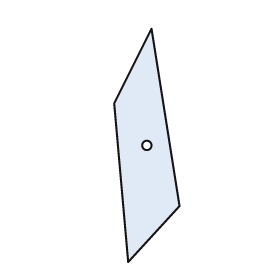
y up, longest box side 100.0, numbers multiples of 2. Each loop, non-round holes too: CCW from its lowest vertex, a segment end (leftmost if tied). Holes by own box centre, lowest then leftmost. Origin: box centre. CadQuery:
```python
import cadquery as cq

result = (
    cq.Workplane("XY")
    .moveTo(-8.0, -50.0)
    .lineTo(14.0, -26.0)
    .lineTo(2.0, 50.0)
    .lineTo(-14.0, 18.0)
    .close()
    .moveTo(0.0, 0.0)
    .circle(2.0)
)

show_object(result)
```